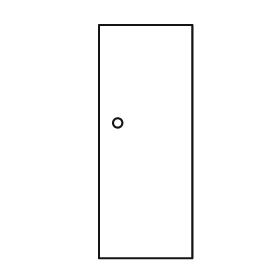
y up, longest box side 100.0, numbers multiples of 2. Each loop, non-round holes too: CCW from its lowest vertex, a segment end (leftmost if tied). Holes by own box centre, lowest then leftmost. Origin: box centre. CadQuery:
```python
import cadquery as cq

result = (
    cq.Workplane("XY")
    .moveTo(-20.0, -50.0)
    .lineTo(20.0, -50.0)
    .lineTo(20.0, 50.0)
    .lineTo(-20.0, 50.0)
    .close()
    .moveTo(-12.0, 8.0)
    .circle(2.0)
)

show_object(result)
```